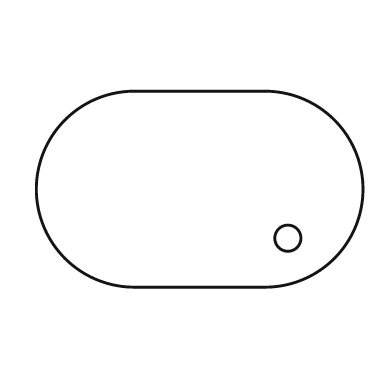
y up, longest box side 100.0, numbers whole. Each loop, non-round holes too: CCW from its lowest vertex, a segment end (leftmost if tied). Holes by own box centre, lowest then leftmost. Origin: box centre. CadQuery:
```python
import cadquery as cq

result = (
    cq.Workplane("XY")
    .moveTo(-20.0, -30.0)
    .lineTo(20.0, -30.0)
    .threePointArc((50.0, 0.0), (20.0, 30.0))
    .lineTo(-20.0, 30.0)
    .threePointArc((-50.0, 0.0), (-20.0, -30.0))
    .close()
    .moveTo(27.0, -15.0)
    .circle(4.0)
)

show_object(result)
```